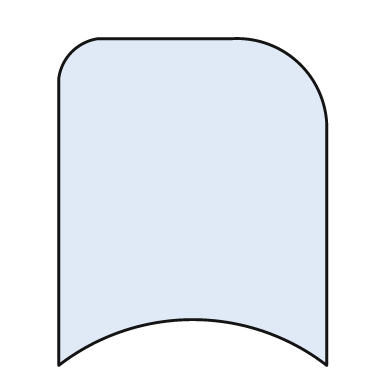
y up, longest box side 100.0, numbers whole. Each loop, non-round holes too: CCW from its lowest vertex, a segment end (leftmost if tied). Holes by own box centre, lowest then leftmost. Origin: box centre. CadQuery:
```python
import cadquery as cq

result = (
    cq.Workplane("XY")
    .moveTo(-41.0, -50.0)
    .threePointArc((0.0, -36.0), (41.0, -50.0))
    .lineTo(41.0, 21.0)
    .threePointArc((33.0, 42.0), (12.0, 50.0))
    .lineTo(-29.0, 50.0)
    .threePointArc((-37.0, 46.0), (-41.0, 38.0))
    .close()
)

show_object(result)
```